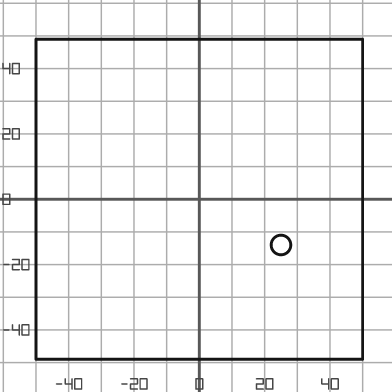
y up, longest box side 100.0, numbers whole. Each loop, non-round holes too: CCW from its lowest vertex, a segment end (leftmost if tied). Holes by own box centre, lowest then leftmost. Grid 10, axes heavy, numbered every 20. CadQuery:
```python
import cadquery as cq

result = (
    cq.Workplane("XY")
    .moveTo(-50.0, -49.0)
    .lineTo(50.0, -49.0)
    .lineTo(50.0, 49.0)
    .lineTo(-50.0, 49.0)
    .close()
    .moveTo(25.0, -14.0)
    .circle(3.0)
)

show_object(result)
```